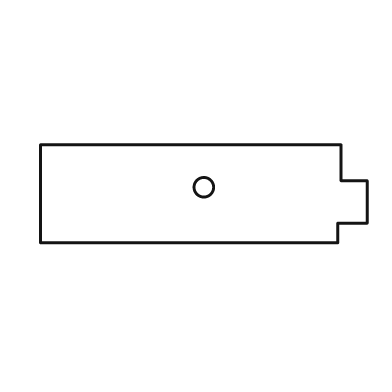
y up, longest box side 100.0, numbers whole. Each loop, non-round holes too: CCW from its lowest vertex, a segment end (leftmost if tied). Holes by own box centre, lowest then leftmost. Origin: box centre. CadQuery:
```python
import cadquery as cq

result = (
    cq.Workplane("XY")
    .moveTo(-50.0, -15.0)
    .lineTo(41.0, -15.0)
    .lineTo(41.0, -9.0)
    .lineTo(50.0, -9.0)
    .lineTo(50.0, 4.0)
    .lineTo(42.0, 4.0)
    .lineTo(42.0, 15.0)
    .lineTo(-50.0, 15.0)
    .close()
    .moveTo(0.0, 2.0)
    .circle(3.0)
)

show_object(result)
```